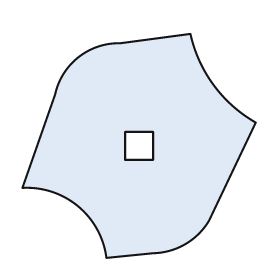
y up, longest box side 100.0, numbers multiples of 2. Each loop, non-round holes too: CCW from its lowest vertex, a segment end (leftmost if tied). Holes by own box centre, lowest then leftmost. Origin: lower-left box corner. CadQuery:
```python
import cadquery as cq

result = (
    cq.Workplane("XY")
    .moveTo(36.0, 0.0)
    .lineTo(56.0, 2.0)
    .threePointArc((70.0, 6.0), (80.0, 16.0))
    .lineTo(100.0, 58.0)
    .threePointArc((82.0, 74.0), (72.0, 96.0))
    .lineTo(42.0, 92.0)
    .threePointArc((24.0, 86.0), (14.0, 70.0))
    .lineTo(0.0, 30.0)
    .threePointArc((24.0, 22.0), (36.0, 0.0))
    .close()
    .moveTo(44.0, 42.0)
    .lineTo(56.0, 42.0)
    .lineTo(56.0, 54.0)
    .lineTo(44.0, 54.0)
    .close()
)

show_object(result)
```